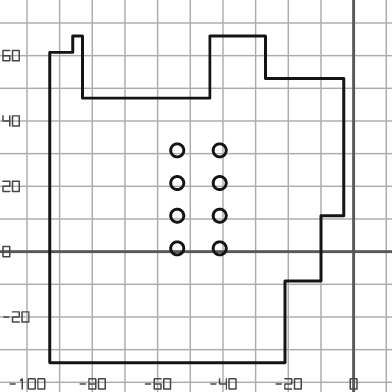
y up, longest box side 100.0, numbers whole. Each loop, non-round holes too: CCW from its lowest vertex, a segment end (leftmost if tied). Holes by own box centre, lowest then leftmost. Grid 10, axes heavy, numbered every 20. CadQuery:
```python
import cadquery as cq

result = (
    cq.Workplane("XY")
    .moveTo(-93.0, -34.0)
    .lineTo(-21.0, -34.0)
    .lineTo(-21.0, -9.0)
    .lineTo(-10.0, -9.0)
    .lineTo(-10.0, 11.0)
    .lineTo(-3.0, 11.0)
    .lineTo(-3.0, 53.0)
    .lineTo(-27.0, 53.0)
    .lineTo(-27.0, 66.0)
    .lineTo(-44.0, 66.0)
    .lineTo(-44.0, 47.0)
    .lineTo(-83.0, 47.0)
    .lineTo(-83.0, 66.0)
    .lineTo(-86.0, 66.0)
    .lineTo(-86.0, 61.0)
    .lineTo(-93.0, 61.0)
    .close()
    .moveTo(-54.0, 1.0)
    .circle(2.0)
    .moveTo(-41.0, 1.0)
    .circle(2.0)
    .moveTo(-54.0, 11.0)
    .circle(2.0)
    .moveTo(-41.0, 11.0)
    .circle(2.0)
    .moveTo(-54.0, 21.0)
    .circle(2.0)
    .moveTo(-41.0, 21.0)
    .circle(2.0)
    .moveTo(-54.0, 31.0)
    .circle(2.0)
    .moveTo(-41.0, 31.0)
    .circle(2.0)
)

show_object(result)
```